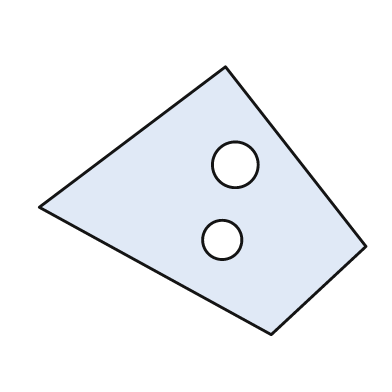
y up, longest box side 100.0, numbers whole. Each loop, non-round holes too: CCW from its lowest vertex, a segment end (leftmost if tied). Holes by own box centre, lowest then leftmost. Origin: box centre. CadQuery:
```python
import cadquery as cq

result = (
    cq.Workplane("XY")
    .moveTo(21.0, -41.0)
    .lineTo(50.0, -14.0)
    .lineTo(7.0, 41.0)
    .lineTo(-50.0, -2.0)
    .close()
    .moveTo(6.0, -12.0)
    .circle(6.0)
    .moveTo(10.0, 11.0)
    .circle(7.0)
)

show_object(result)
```